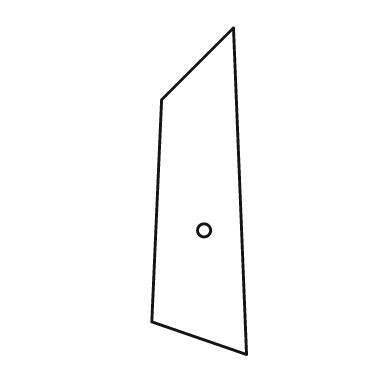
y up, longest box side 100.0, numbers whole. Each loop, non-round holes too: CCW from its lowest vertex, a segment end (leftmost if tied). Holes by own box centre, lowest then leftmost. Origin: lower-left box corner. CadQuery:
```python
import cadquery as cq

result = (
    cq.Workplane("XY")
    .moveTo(29.0, 0.0)
    .lineTo(25.0, 100.0)
    .lineTo(3.0, 78.0)
    .lineTo(0.0, 10.0)
    .close()
    .moveTo(16.0, 38.0)
    .circle(2.0)
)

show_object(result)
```